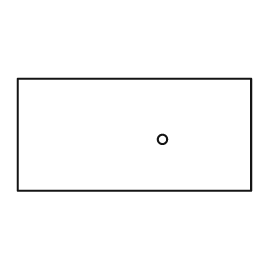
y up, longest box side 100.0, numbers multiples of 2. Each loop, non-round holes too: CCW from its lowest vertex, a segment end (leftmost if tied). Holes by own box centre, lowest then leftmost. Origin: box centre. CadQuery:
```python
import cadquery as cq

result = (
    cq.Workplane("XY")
    .moveTo(-50.0, -24.0)
    .lineTo(50.0, -24.0)
    .lineTo(50.0, 24.0)
    .lineTo(-50.0, 24.0)
    .close()
    .moveTo(12.0, -2.0)
    .circle(2.0)
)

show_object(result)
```